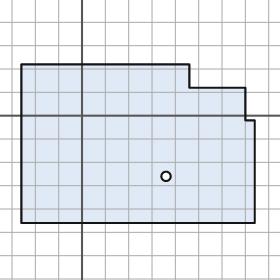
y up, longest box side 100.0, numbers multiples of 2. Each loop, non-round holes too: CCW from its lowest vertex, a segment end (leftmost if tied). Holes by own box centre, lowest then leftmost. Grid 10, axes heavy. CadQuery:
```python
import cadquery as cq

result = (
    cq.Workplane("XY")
    .moveTo(-26.0, -46.0)
    .lineTo(74.0, -46.0)
    .lineTo(74.0, -2.0)
    .lineTo(70.0, -2.0)
    .lineTo(70.0, 12.0)
    .lineTo(46.0, 12.0)
    .lineTo(46.0, 22.0)
    .lineTo(-26.0, 22.0)
    .close()
    .moveTo(36.0, -26.0)
    .circle(2.0)
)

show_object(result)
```